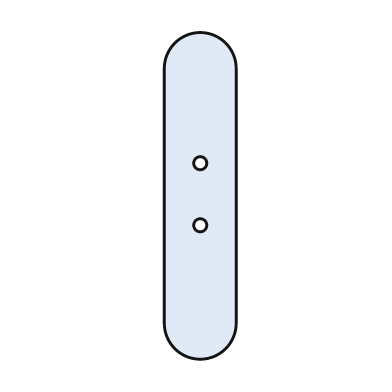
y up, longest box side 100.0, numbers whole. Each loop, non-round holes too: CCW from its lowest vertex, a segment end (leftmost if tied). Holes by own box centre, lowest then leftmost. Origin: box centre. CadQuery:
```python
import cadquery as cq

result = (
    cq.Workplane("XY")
    .moveTo(-11.0, -39.0)
    .threePointArc((0.0, -50.0), (11.0, -39.0))
    .lineTo(11.0, 39.0)
    .threePointArc((0.0, 50.0), (-11.0, 39.0))
    .close()
    .moveTo(0.0, -9.0)
    .circle(2.0)
    .moveTo(0.0, 10.0)
    .circle(2.0)
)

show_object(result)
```